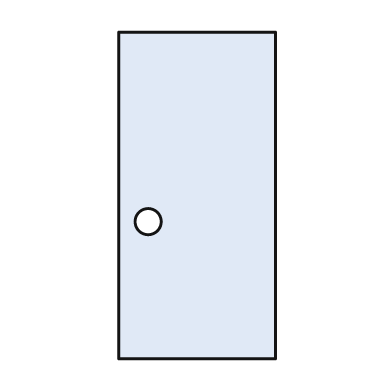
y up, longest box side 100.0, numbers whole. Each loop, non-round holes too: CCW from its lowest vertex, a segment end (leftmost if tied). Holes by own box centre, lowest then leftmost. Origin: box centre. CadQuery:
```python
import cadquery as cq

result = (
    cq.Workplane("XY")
    .moveTo(-24.0, -50.0)
    .lineTo(24.0, -50.0)
    .lineTo(24.0, 50.0)
    .lineTo(-24.0, 50.0)
    .close()
    .moveTo(-15.0, -8.0)
    .circle(4.0)
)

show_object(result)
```